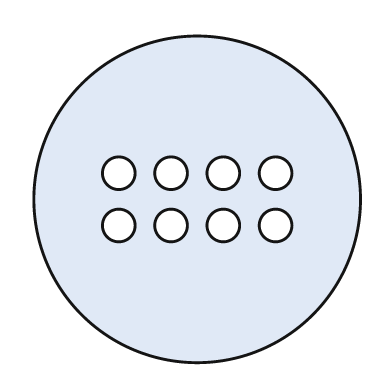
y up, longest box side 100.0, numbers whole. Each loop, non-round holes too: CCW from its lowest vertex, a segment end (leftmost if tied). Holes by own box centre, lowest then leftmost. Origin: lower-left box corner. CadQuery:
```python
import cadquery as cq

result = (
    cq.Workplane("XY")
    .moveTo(50.0, 50.0)
    .circle(50.0)
    .moveTo(26.0, 42.0)
    .circle(5.0)
    .moveTo(42.0, 42.0)
    .circle(5.0)
    .moveTo(58.0, 42.0)
    .circle(5.0)
    .moveTo(74.0, 42.0)
    .circle(5.0)
    .moveTo(26.0, 58.0)
    .circle(5.0)
    .moveTo(42.0, 58.0)
    .circle(5.0)
    .moveTo(58.0, 58.0)
    .circle(5.0)
    .moveTo(74.0, 58.0)
    .circle(5.0)
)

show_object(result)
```